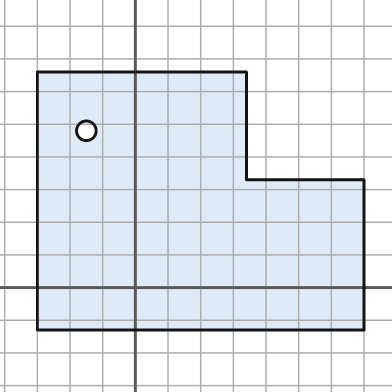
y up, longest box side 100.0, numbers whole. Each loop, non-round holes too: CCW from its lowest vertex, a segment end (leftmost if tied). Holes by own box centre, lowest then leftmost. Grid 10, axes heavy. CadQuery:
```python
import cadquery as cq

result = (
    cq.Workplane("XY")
    .moveTo(-30.0, -13.0)
    .lineTo(70.0, -13.0)
    .lineTo(70.0, 33.0)
    .lineTo(34.0, 33.0)
    .lineTo(34.0, 66.0)
    .lineTo(-30.0, 66.0)
    .close()
    .moveTo(-15.0, 48.0)
    .circle(3.0)
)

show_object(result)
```